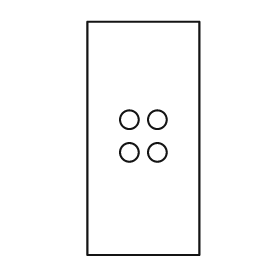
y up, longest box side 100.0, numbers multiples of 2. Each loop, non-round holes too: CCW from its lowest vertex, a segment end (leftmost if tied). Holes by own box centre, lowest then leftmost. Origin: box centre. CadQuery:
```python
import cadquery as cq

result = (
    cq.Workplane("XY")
    .moveTo(-24.0, -50.0)
    .lineTo(24.0, -50.0)
    .lineTo(24.0, 50.0)
    .lineTo(-24.0, 50.0)
    .close()
    .moveTo(-6.0, -6.0)
    .circle(4.0)
    .moveTo(6.0, -6.0)
    .circle(4.0)
    .moveTo(-6.0, 8.0)
    .circle(4.0)
    .moveTo(6.0, 8.0)
    .circle(4.0)
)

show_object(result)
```